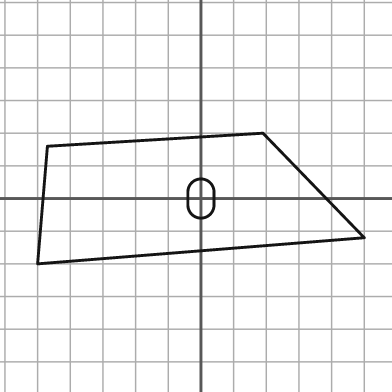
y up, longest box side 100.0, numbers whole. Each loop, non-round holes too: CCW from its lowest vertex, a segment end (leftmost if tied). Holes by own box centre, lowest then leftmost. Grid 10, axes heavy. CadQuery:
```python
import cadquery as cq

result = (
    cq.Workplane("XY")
    .moveTo(-50.0, -20.0)
    .lineTo(50.0, -12.0)
    .lineTo(19.0, 20.0)
    .lineTo(-47.0, 16.0)
    .close()
    .moveTo(-4.0, -2.0)
    .threePointArc((0.0, -6.0), (4.0, -2.0))
    .lineTo(4.0, 2.0)
    .threePointArc((0.0, 6.0), (-4.0, 2.0))
    .close()
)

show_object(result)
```